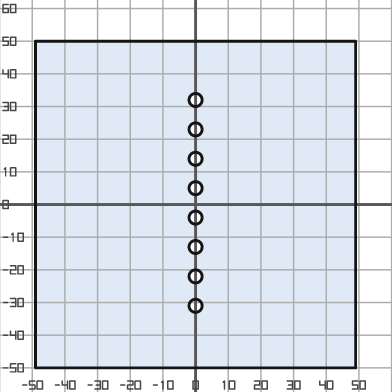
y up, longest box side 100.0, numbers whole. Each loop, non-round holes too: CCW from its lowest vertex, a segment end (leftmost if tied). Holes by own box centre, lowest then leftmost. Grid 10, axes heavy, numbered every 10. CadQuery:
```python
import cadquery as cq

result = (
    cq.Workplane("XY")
    .moveTo(-49.0, -50.0)
    .lineTo(49.0, -50.0)
    .lineTo(49.0, 50.0)
    .lineTo(-49.0, 50.0)
    .close()
    .moveTo(0.0, -31.0)
    .circle(2.0)
    .moveTo(0.0, -22.0)
    .circle(2.0)
    .moveTo(0.0, -13.0)
    .circle(2.0)
    .moveTo(0.0, -4.0)
    .circle(2.0)
    .moveTo(0.0, 5.0)
    .circle(2.0)
    .moveTo(0.0, 14.0)
    .circle(2.0)
    .moveTo(0.0, 23.0)
    .circle(2.0)
    .moveTo(0.0, 32.0)
    .circle(2.0)
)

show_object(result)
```